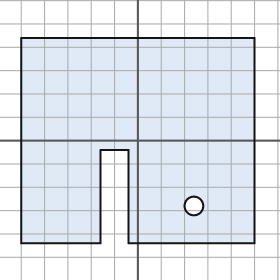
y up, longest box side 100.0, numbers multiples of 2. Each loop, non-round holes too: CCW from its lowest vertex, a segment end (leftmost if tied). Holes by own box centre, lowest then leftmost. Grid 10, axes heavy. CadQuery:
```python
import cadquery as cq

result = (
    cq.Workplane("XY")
    .moveTo(-50.0, -44.0)
    .lineTo(-16.0, -44.0)
    .lineTo(-16.0, -4.0)
    .lineTo(-4.0, -4.0)
    .lineTo(-4.0, -44.0)
    .lineTo(50.0, -44.0)
    .lineTo(50.0, 44.0)
    .lineTo(-50.0, 44.0)
    .close()
    .moveTo(24.0, -28.0)
    .circle(4.0)
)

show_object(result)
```